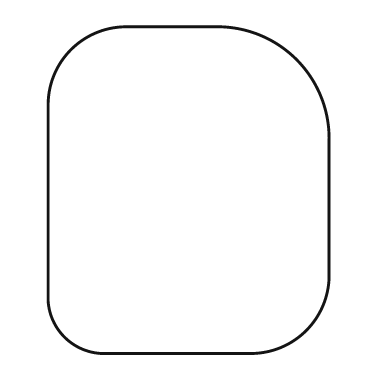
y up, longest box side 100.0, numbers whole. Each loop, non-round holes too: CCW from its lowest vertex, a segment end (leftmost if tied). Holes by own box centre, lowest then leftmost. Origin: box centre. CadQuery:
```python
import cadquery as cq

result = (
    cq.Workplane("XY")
    .moveTo(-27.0, -50.0)
    .lineTo(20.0, -50.0)
    .threePointArc((36.0, -43.0), (43.0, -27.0))
    .lineTo(43.0, 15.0)
    .threePointArc((33.0, 40.0), (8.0, 50.0))
    .lineTo(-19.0, 50.0)
    .threePointArc((-36.0, 43.0), (-43.0, 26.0))
    .lineTo(-43.0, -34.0)
    .threePointArc((-38.0, -45.0), (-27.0, -50.0))
    .close()
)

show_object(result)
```